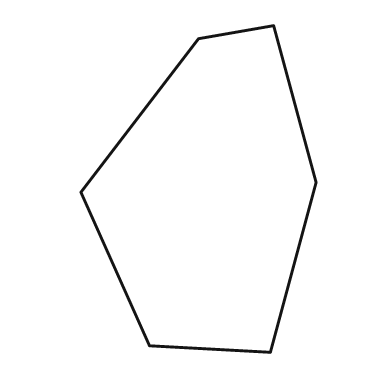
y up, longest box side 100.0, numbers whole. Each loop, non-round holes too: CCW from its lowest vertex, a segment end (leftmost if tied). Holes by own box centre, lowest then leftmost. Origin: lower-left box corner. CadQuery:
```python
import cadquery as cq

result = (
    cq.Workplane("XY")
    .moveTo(58.0, 0.0)
    .lineTo(72.0, 52.0)
    .lineTo(59.0, 100.0)
    .lineTo(36.0, 96.0)
    .lineTo(0.0, 49.0)
    .lineTo(21.0, 2.0)
    .close()
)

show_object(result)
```